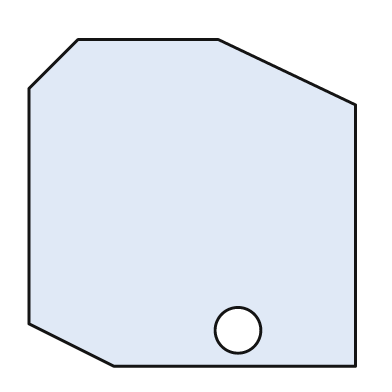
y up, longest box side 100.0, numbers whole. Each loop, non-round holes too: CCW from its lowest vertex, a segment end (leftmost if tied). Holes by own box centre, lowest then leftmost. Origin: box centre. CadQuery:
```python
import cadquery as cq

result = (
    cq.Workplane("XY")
    .moveTo(-24.0, -50.0)
    .lineTo(50.0, -50.0)
    .lineTo(50.0, 30.0)
    .lineTo(8.0, 50.0)
    .lineTo(-35.0, 50.0)
    .lineTo(-50.0, 35.0)
    .lineTo(-50.0, -37.0)
    .close()
    .moveTo(14.0, -39.0)
    .circle(7.0)
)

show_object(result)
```